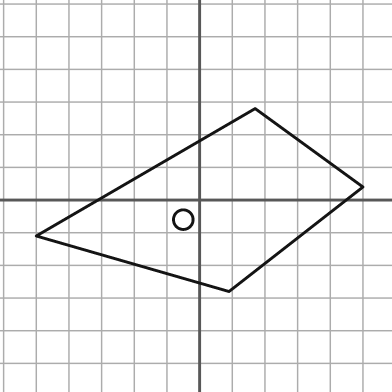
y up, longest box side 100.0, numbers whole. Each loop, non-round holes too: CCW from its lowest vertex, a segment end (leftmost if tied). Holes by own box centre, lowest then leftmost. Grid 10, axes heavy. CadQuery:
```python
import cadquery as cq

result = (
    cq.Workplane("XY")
    .moveTo(9.0, -28.0)
    .lineTo(50.0, 4.0)
    .lineTo(17.0, 28.0)
    .lineTo(-50.0, -11.0)
    .close()
    .moveTo(-5.0, -6.0)
    .circle(3.0)
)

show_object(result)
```